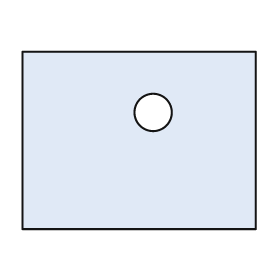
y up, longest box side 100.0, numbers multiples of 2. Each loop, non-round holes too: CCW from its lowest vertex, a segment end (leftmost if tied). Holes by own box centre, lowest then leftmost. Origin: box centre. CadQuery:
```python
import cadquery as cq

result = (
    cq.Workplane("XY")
    .moveTo(-50.0, -38.0)
    .lineTo(50.0, -38.0)
    .lineTo(50.0, 38.0)
    .lineTo(-50.0, 38.0)
    .close()
    .moveTo(6.0, 12.0)
    .circle(8.0)
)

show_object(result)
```